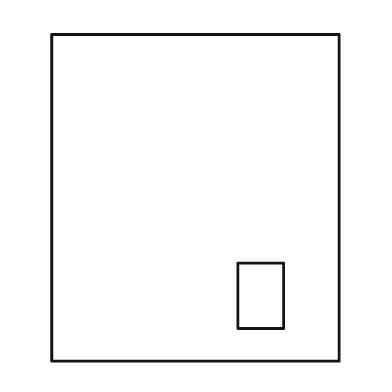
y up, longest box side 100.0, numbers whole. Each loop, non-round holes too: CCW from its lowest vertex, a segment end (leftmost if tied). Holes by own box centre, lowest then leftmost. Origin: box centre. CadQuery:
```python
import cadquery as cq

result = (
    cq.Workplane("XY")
    .moveTo(-44.0, -50.0)
    .lineTo(44.0, -50.0)
    .lineTo(44.0, 50.0)
    .lineTo(-44.0, 50.0)
    .close()
    .moveTo(13.0, -40.0)
    .lineTo(27.0, -40.0)
    .lineTo(27.0, -20.0)
    .lineTo(13.0, -20.0)
    .close()
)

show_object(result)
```